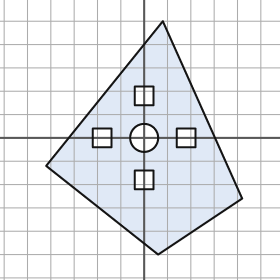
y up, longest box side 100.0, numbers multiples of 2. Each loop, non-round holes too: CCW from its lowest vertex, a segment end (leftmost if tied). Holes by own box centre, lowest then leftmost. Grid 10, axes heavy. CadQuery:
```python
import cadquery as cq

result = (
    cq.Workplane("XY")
    .moveTo(6.0, -50.0)
    .lineTo(42.0, -26.0)
    .lineTo(8.0, 50.0)
    .lineTo(-42.0, -12.0)
    .close()
    .moveTo(-4.0, -22.0)
    .lineTo(4.0, -22.0)
    .lineTo(4.0, -14.0)
    .lineTo(-4.0, -14.0)
    .close()
    .moveTo(-22.0, -4.0)
    .lineTo(-14.0, -4.0)
    .lineTo(-14.0, 4.0)
    .lineTo(-22.0, 4.0)
    .close()
    .moveTo(0.0, 0.0)
    .circle(6.0)
    .moveTo(14.0, -4.0)
    .lineTo(22.0, -4.0)
    .lineTo(22.0, 4.0)
    .lineTo(14.0, 4.0)
    .close()
    .moveTo(-4.0, 14.0)
    .lineTo(4.0, 14.0)
    .lineTo(4.0, 22.0)
    .lineTo(-4.0, 22.0)
    .close()
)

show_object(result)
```